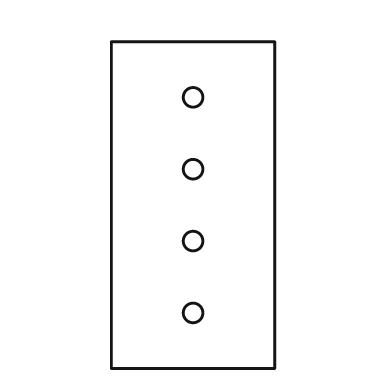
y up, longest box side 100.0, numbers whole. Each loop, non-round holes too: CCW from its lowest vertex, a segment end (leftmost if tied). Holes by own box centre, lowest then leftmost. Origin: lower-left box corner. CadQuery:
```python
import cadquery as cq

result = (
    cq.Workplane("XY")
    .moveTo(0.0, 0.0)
    .lineTo(50.0, 0.0)
    .lineTo(50.0, 100.0)
    .lineTo(0.0, 100.0)
    .close()
    .moveTo(25.0, 17.0)
    .circle(3.0)
    .moveTo(25.0, 39.0)
    .circle(3.0)
    .moveTo(25.0, 61.0)
    .circle(3.0)
    .moveTo(25.0, 83.0)
    .circle(3.0)
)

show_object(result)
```